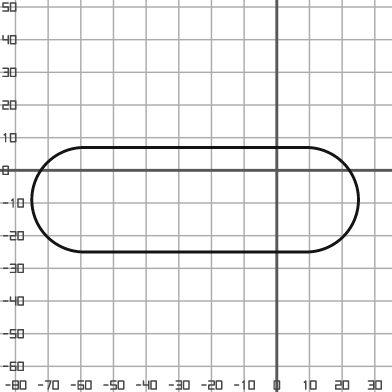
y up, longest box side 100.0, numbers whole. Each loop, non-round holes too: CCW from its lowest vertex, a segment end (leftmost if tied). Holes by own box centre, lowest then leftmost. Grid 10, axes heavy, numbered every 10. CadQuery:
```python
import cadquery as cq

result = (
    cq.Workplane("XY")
    .moveTo(-59.0, -25.0)
    .lineTo(9.0, -25.0)
    .threePointArc((25.0, -9.0), (9.0, 7.0))
    .lineTo(-59.0, 7.0)
    .threePointArc((-75.0, -9.0), (-59.0, -25.0))
    .close()
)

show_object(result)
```